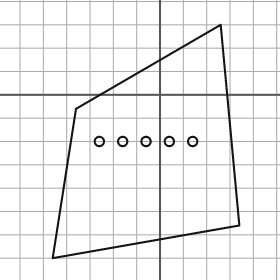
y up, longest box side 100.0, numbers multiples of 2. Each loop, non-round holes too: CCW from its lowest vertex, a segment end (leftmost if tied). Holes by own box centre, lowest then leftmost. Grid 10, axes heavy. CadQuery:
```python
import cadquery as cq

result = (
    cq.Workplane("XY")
    .moveTo(-46.0, -70.0)
    .lineTo(34.0, -56.0)
    .lineTo(26.0, 30.0)
    .lineTo(-36.0, -6.0)
    .close()
    .moveTo(-26.0, -20.0)
    .circle(2.0)
    .moveTo(-16.0, -20.0)
    .circle(2.0)
    .moveTo(-6.0, -20.0)
    .circle(2.0)
    .moveTo(4.0, -20.0)
    .circle(2.0)
    .moveTo(14.0, -20.0)
    .circle(2.0)
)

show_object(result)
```